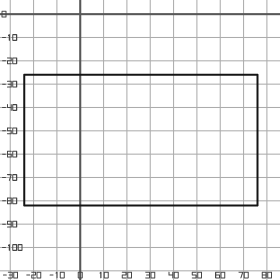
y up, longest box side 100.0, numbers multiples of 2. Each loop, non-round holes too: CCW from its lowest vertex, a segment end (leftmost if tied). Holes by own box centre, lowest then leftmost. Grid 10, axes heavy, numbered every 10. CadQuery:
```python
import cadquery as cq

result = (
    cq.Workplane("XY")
    .moveTo(-24.0, -82.0)
    .lineTo(76.0, -82.0)
    .lineTo(76.0, -26.0)
    .lineTo(-24.0, -26.0)
    .close()
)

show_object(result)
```